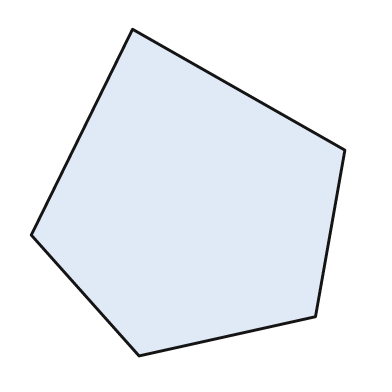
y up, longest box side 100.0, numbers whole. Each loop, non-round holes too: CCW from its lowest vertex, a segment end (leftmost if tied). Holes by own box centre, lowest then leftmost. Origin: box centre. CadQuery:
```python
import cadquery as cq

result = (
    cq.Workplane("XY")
    .moveTo(-15.0, -50.0)
    .lineTo(39.0, -38.0)
    .lineTo(48.0, 13.0)
    .lineTo(-17.0, 50.0)
    .lineTo(-48.0, -13.0)
    .close()
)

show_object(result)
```